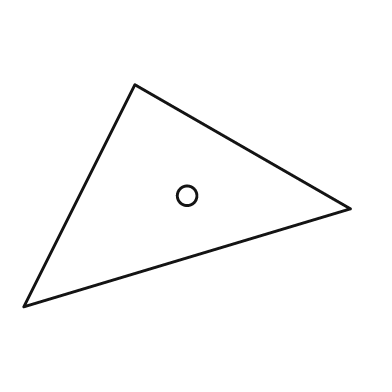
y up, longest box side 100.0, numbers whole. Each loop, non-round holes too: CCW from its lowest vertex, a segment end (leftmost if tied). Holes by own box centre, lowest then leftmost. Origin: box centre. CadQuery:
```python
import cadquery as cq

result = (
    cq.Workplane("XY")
    .moveTo(-50.0, -34.0)
    .lineTo(50.0, -4.0)
    .lineTo(-16.0, 34.0)
    .close()
    .moveTo(0.0, 0.0)
    .circle(3.0)
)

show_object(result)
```